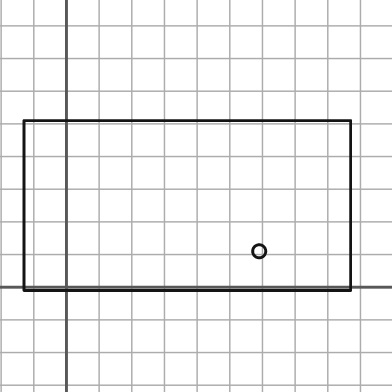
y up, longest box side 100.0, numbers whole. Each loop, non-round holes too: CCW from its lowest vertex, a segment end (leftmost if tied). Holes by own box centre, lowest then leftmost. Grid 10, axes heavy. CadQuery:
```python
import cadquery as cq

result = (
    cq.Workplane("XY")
    .moveTo(-13.0, -1.0)
    .lineTo(87.0, -1.0)
    .lineTo(87.0, 51.0)
    .lineTo(-13.0, 51.0)
    .close()
    .moveTo(59.0, 11.0)
    .circle(2.0)
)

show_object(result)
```